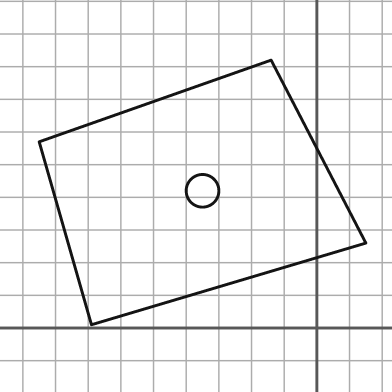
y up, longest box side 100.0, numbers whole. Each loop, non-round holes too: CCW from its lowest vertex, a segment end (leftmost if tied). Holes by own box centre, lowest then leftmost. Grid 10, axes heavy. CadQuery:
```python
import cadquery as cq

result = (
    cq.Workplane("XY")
    .moveTo(-69.0, 1.0)
    .lineTo(15.0, 26.0)
    .lineTo(-14.0, 82.0)
    .lineTo(-85.0, 57.0)
    .close()
    .moveTo(-35.0, 42.0)
    .circle(5.0)
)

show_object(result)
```